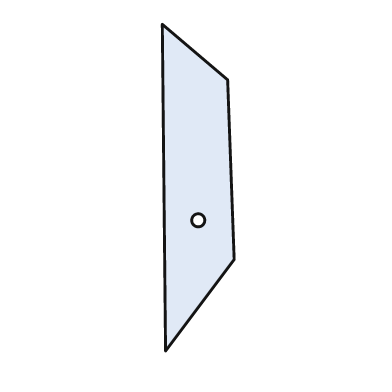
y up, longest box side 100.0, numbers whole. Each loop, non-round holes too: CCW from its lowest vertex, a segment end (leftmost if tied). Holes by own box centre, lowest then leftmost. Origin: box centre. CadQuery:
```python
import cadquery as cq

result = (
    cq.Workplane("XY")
    .moveTo(-10.0, -50.0)
    .lineTo(11.0, -22.0)
    .lineTo(9.0, 33.0)
    .lineTo(-11.0, 50.0)
    .close()
    .moveTo(0.0, -10.0)
    .circle(2.0)
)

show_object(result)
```